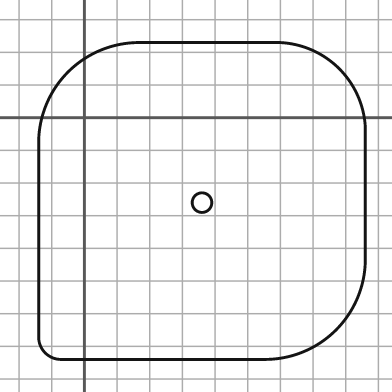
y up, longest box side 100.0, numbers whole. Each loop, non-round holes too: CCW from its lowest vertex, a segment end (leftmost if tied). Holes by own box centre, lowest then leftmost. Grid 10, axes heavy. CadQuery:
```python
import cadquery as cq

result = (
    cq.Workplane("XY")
    .moveTo(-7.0, -74.0)
    .lineTo(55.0, -74.0)
    .threePointArc((77.0, -65.0), (86.0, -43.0))
    .lineTo(86.0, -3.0)
    .threePointArc((78.0, 15.0), (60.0, 23.0))
    .lineTo(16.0, 23.0)
    .threePointArc((-5.0, 14.0), (-14.0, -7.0))
    .lineTo(-14.0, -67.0)
    .threePointArc((-12.0, -72.0), (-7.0, -74.0))
    .close()
    .moveTo(36.0, -26.0)
    .circle(3.0)
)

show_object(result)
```